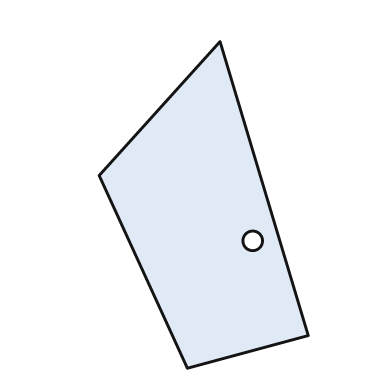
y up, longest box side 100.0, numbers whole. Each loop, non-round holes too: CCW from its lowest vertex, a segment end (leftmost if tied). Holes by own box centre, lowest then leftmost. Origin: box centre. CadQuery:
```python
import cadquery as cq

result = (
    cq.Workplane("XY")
    .moveTo(-5.0, -50.0)
    .lineTo(32.0, -40.0)
    .lineTo(5.0, 50.0)
    .lineTo(-32.0, 9.0)
    .close()
    .moveTo(15.0, -11.0)
    .circle(3.0)
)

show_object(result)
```